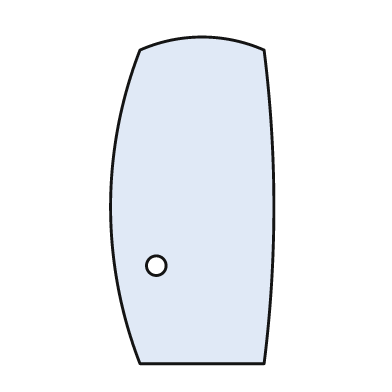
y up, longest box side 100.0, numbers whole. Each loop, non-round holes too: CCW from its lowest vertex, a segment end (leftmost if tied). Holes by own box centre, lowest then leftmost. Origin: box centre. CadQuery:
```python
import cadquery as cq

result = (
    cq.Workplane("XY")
    .moveTo(-16.0, -50.0)
    .lineTo(22.0, -50.0)
    .threePointArc((25.0, -2.0), (22.0, 46.0))
    .threePointArc((3.0, 50.0), (-16.0, 46.0))
    .threePointArc((-25.0, -2.0), (-16.0, -50.0))
    .close()
    .moveTo(-11.0, -20.0)
    .circle(3.0)
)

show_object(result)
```